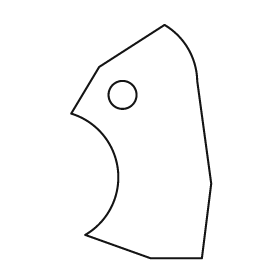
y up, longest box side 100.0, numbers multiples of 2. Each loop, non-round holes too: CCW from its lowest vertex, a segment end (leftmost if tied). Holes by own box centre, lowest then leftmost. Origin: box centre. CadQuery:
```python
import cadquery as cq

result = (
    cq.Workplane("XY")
    .moveTo(4.0, -50.0)
    .lineTo(26.0, -50.0)
    .lineTo(30.0, -18.0)
    .lineTo(24.0, 26.0)
    .threePointArc((20.0, 40.0), (10.0, 50.0))
    .lineTo(-18.0, 32.0)
    .lineTo(-30.0, 12.0)
    .threePointArc((-10.0, -12.0), (-24.0, -40.0))
    .close()
    .moveTo(-8.0, 20.0)
    .circle(6.0)
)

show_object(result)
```